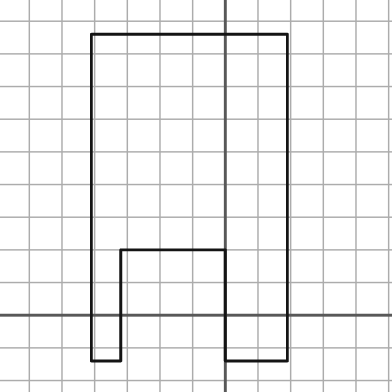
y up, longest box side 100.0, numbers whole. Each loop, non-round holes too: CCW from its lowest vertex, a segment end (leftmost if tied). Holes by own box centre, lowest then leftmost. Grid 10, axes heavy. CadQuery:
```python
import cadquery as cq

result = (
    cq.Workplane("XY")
    .moveTo(-41.0, -14.0)
    .lineTo(-32.0, -14.0)
    .lineTo(-32.0, 20.0)
    .lineTo(0.0, 20.0)
    .lineTo(0.0, -14.0)
    .lineTo(19.0, -14.0)
    .lineTo(19.0, 86.0)
    .lineTo(-41.0, 86.0)
    .close()
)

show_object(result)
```